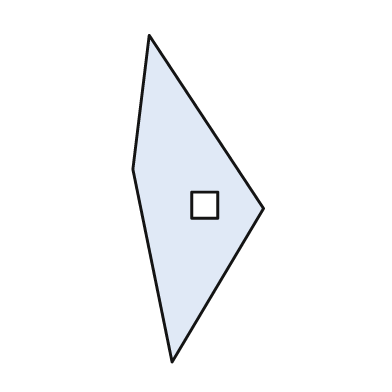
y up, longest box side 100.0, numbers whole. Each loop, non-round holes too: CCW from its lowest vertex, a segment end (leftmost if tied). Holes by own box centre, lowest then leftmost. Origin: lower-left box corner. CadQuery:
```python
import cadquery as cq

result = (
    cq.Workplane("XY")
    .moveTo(12.0, 0.0)
    .lineTo(40.0, 47.0)
    .lineTo(5.0, 100.0)
    .lineTo(0.0, 59.0)
    .close()
    .moveTo(18.0, 44.0)
    .lineTo(26.0, 44.0)
    .lineTo(26.0, 52.0)
    .lineTo(18.0, 52.0)
    .close()
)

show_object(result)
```